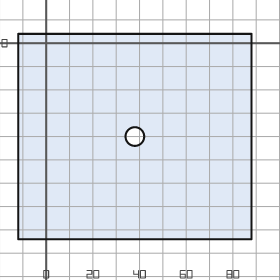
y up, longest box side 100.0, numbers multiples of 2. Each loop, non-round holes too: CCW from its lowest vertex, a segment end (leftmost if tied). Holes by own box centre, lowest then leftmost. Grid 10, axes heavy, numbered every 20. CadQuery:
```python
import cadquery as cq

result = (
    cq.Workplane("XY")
    .moveTo(-12.0, -84.0)
    .lineTo(88.0, -84.0)
    .lineTo(88.0, 4.0)
    .lineTo(-12.0, 4.0)
    .close()
    .moveTo(38.0, -40.0)
    .circle(4.0)
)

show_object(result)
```